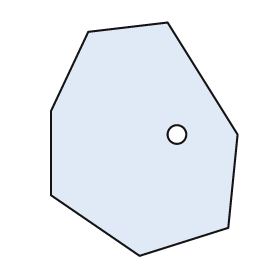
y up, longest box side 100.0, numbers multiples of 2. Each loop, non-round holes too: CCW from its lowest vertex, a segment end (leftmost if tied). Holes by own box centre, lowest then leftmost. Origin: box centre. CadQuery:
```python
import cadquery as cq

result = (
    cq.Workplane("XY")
    .moveTo(-2.0, -50.0)
    .lineTo(36.0, -38.0)
    .lineTo(40.0, 2.0)
    .lineTo(10.0, 50.0)
    .lineTo(-24.0, 46.0)
    .lineTo(-40.0, 12.0)
    .lineTo(-40.0, -24.0)
    .close()
    .moveTo(14.0, 2.0)
    .circle(4.0)
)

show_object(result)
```